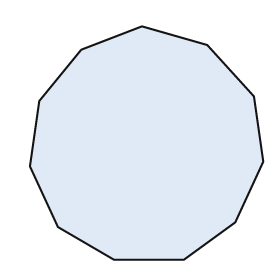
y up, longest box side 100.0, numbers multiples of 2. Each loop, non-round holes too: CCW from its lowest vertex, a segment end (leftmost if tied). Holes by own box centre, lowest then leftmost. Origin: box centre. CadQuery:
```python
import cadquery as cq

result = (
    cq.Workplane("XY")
    .moveTo(-14.0, -50.0)
    .lineTo(16.0, -50.0)
    .lineTo(38.0, -34.0)
    .lineTo(50.0, -8.0)
    .lineTo(46.0, 20.0)
    .lineTo(26.0, 42.0)
    .lineTo(-2.0, 50.0)
    .lineTo(-28.0, 40.0)
    .lineTo(-46.0, 18.0)
    .lineTo(-50.0, -10.0)
    .lineTo(-38.0, -36.0)
    .close()
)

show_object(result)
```